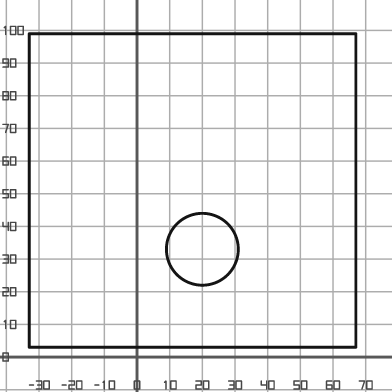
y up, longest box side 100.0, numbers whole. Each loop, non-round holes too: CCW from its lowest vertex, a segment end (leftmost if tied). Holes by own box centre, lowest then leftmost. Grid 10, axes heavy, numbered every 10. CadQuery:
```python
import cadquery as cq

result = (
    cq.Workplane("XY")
    .moveTo(-33.0, 3.0)
    .lineTo(67.0, 3.0)
    .lineTo(67.0, 99.0)
    .lineTo(-33.0, 99.0)
    .close()
    .moveTo(20.0, 33.0)
    .circle(11.0)
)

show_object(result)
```